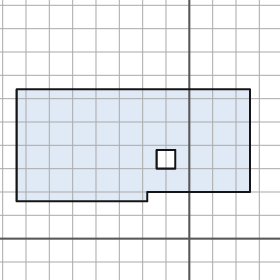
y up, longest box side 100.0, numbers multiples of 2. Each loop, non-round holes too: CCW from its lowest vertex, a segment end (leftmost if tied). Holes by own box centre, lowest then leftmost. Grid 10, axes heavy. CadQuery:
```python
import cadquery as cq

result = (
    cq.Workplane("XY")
    .moveTo(-74.0, 16.0)
    .lineTo(-18.0, 16.0)
    .lineTo(-18.0, 20.0)
    .lineTo(26.0, 20.0)
    .lineTo(26.0, 64.0)
    .lineTo(-74.0, 64.0)
    .close()
    .moveTo(-14.0, 30.0)
    .lineTo(-6.0, 30.0)
    .lineTo(-6.0, 38.0)
    .lineTo(-14.0, 38.0)
    .close()
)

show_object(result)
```